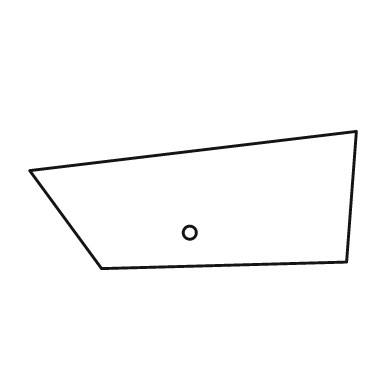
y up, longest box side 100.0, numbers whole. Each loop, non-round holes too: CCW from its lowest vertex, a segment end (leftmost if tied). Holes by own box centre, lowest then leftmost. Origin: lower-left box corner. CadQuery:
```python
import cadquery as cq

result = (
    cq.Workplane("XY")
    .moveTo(22.0, 0.0)
    .lineTo(97.0, 2.0)
    .lineTo(100.0, 42.0)
    .lineTo(0.0, 30.0)
    .close()
    .moveTo(49.0, 11.0)
    .circle(2.0)
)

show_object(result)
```